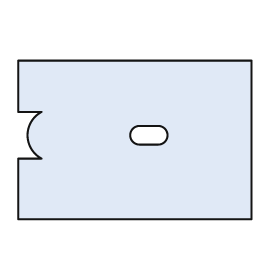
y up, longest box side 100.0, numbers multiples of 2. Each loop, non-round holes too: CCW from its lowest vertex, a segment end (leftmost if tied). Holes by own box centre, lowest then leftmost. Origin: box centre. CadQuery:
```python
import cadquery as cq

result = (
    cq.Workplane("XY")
    .moveTo(-50.0, -34.0)
    .lineTo(50.0, -34.0)
    .lineTo(50.0, 34.0)
    .lineTo(-50.0, 34.0)
    .lineTo(-50.0, 12.0)
    .lineTo(-40.0, 12.0)
    .threePointArc((-46.0, 2.0), (-40.0, -8.0))
    .lineTo(-50.0, -8.0)
    .close()
    .moveTo(2.0, -2.0)
    .lineTo(10.0, -2.0)
    .threePointArc((14.0, 2.0), (10.0, 6.0))
    .lineTo(2.0, 6.0)
    .threePointArc((-2.0, 2.0), (2.0, -2.0))
    .close()
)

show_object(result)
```